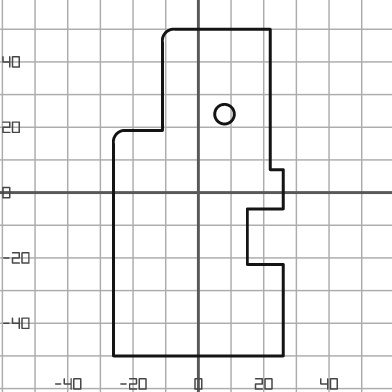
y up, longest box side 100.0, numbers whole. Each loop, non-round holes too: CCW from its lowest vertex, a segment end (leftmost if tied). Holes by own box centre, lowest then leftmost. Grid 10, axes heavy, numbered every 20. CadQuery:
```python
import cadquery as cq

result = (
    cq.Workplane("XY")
    .moveTo(-26.0, -50.0)
    .lineTo(26.0, -50.0)
    .lineTo(26.0, -22.0)
    .lineTo(15.0, -22.0)
    .lineTo(15.0, -5.0)
    .lineTo(26.0, -5.0)
    .lineTo(26.0, 7.0)
    .lineTo(22.0, 7.0)
    .lineTo(22.0, 50.0)
    .lineTo(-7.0, 50.0)
    .threePointArc((-10.0, 49.0), (-11.0, 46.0))
    .lineTo(-11.0, 19.0)
    .lineTo(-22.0, 19.0)
    .threePointArc((-25.0, 18.0), (-26.0, 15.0))
    .close()
    .moveTo(8.0, 24.0)
    .circle(3.0)
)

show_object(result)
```